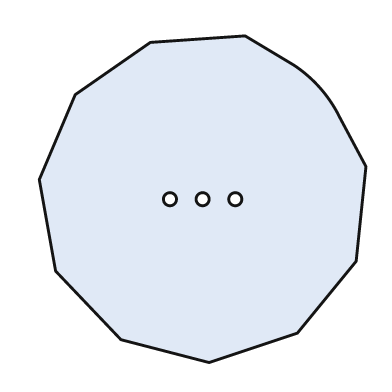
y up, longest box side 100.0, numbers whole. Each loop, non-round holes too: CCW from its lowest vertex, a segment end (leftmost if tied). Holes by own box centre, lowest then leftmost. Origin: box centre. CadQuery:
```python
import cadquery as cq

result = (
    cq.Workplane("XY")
    .moveTo(2.0, -50.0)
    .lineTo(29.0, -41.0)
    .lineTo(47.0, -19.0)
    .lineTo(50.0, 10.0)
    .lineTo(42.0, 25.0)
    .threePointArc((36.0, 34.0), (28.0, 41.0))
    .lineTo(13.0, 50.0)
    .lineTo(-16.0, 48.0)
    .lineTo(-39.0, 32.0)
    .lineTo(-50.0, 6.0)
    .lineTo(-45.0, -22.0)
    .lineTo(-25.0, -43.0)
    .close()
    .moveTo(-10.0, 0.0)
    .circle(2.0)
    .moveTo(0.0, 0.0)
    .circle(2.0)
    .moveTo(10.0, 0.0)
    .circle(2.0)
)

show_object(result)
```